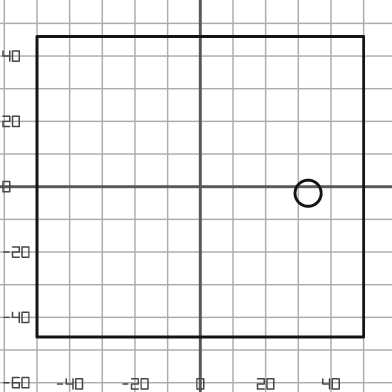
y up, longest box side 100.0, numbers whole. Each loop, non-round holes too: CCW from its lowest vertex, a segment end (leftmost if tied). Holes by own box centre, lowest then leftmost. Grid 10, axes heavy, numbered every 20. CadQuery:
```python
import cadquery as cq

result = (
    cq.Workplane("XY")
    .moveTo(-50.0, -46.0)
    .lineTo(50.0, -46.0)
    .lineTo(50.0, 46.0)
    .lineTo(-50.0, 46.0)
    .close()
    .moveTo(33.0, -2.0)
    .circle(4.0)
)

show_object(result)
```